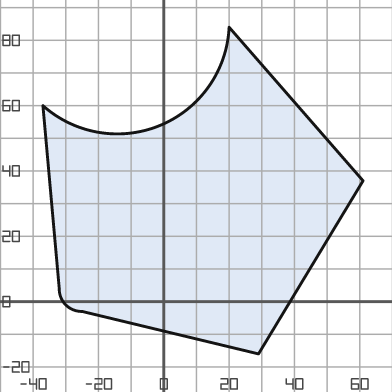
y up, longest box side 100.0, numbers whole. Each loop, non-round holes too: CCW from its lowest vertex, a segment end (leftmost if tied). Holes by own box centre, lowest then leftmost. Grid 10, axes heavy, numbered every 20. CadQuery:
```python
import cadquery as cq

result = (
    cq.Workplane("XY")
    .moveTo(29.0, -16.0)
    .lineTo(61.0, 37.0)
    .lineTo(20.0, 84.0)
    .threePointArc((-1.0, 54.0), (-37.0, 60.0))
    .lineTo(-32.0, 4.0)
    .threePointArc((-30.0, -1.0), (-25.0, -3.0))
    .close()
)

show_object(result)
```